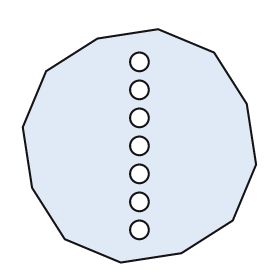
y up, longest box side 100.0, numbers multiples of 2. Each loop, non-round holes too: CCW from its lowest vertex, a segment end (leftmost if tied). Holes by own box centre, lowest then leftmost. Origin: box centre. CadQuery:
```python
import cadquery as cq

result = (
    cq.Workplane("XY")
    .moveTo(-8.0, -50.0)
    .lineTo(18.0, -46.0)
    .lineTo(40.0, -32.0)
    .lineTo(50.0, -8.0)
    .lineTo(46.0, 18.0)
    .lineTo(32.0, 40.0)
    .lineTo(8.0, 50.0)
    .lineTo(-18.0, 46.0)
    .lineTo(-40.0, 32.0)
    .lineTo(-50.0, 8.0)
    .lineTo(-46.0, -18.0)
    .lineTo(-32.0, -40.0)
    .close()
    .moveTo(0.0, -36.0)
    .circle(4.0)
    .moveTo(0.0, -24.0)
    .circle(4.0)
    .moveTo(0.0, -12.0)
    .circle(4.0)
    .moveTo(0.0, 0.0)
    .circle(4.0)
    .moveTo(0.0, 12.0)
    .circle(4.0)
    .moveTo(0.0, 24.0)
    .circle(4.0)
    .moveTo(0.0, 36.0)
    .circle(4.0)
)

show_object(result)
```